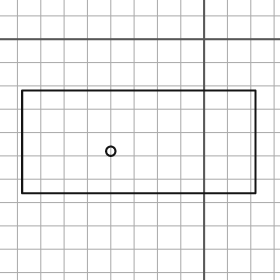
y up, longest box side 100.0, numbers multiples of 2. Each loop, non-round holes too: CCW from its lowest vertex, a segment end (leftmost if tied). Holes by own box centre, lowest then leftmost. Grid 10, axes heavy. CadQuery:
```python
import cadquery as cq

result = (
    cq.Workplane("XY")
    .moveTo(-78.0, -66.0)
    .lineTo(22.0, -66.0)
    .lineTo(22.0, -22.0)
    .lineTo(-78.0, -22.0)
    .close()
    .moveTo(-40.0, -48.0)
    .circle(2.0)
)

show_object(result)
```